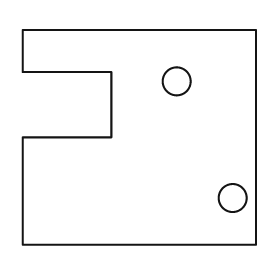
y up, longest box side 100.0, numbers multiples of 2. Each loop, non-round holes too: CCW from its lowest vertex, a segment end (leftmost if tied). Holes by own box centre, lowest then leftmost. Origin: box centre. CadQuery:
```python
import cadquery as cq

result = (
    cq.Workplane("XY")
    .moveTo(-50.0, -46.0)
    .lineTo(50.0, -46.0)
    .lineTo(50.0, 46.0)
    .lineTo(-50.0, 46.0)
    .lineTo(-50.0, 28.0)
    .lineTo(-12.0, 28.0)
    .lineTo(-12.0, 0.0)
    .lineTo(-50.0, 0.0)
    .close()
    .moveTo(40.0, -26.0)
    .circle(6.0)
    .moveTo(16.0, 24.0)
    .circle(6.0)
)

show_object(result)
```